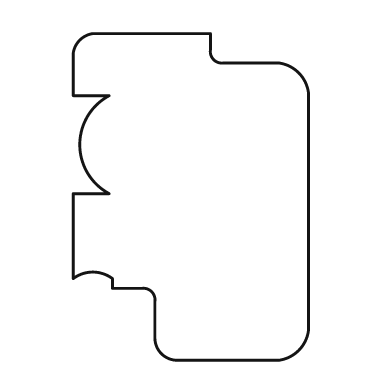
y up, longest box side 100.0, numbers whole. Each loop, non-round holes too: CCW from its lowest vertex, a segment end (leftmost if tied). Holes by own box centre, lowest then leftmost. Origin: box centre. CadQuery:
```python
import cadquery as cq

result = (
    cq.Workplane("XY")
    .moveTo(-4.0, -50.0)
    .lineTo(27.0, -50.0)
    .threePointArc((33.0, -47.0), (36.0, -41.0))
    .lineTo(36.0, 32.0)
    .threePointArc((33.0, 38.0), (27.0, 41.0))
    .lineTo(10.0, 41.0)
    .threePointArc((7.0, 42.0), (6.0, 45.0))
    .lineTo(6.0, 50.0)
    .lineTo(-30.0, 50.0)
    .threePointArc((-34.0, 48.0), (-36.0, 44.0))
    .lineTo(-36.0, 31.0)
    .lineTo(-25.0, 31.0)
    .threePointArc((-34.0, 16.0), (-25.0, 1.0))
    .lineTo(-36.0, 1.0)
    .lineTo(-36.0, -25.0)
    .threePointArc((-30.0, -23.0), (-24.0, -25.0))
    .lineTo(-24.0, -28.0)
    .lineTo(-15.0, -28.0)
    .threePointArc((-12.0, -29.0), (-11.0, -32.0))
    .lineTo(-11.0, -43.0)
    .threePointArc((-9.0, -48.0), (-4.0, -50.0))
    .close()
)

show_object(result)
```